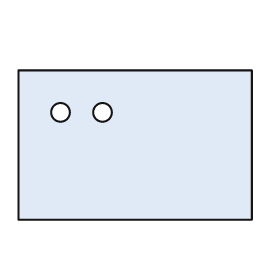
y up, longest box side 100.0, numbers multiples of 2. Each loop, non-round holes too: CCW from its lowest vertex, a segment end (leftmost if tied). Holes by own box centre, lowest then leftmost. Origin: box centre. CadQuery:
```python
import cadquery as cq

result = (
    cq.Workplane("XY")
    .moveTo(-50.0, -32.0)
    .lineTo(50.0, -32.0)
    .lineTo(50.0, 32.0)
    .lineTo(-50.0, 32.0)
    .close()
    .moveTo(-32.0, 14.0)
    .circle(4.0)
    .moveTo(-14.0, 14.0)
    .circle(4.0)
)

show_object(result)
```